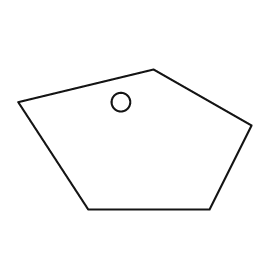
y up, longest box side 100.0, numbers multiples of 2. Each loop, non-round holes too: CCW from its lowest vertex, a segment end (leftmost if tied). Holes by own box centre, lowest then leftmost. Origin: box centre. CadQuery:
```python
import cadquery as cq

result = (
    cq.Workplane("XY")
    .moveTo(-20.0, -30.0)
    .lineTo(32.0, -30.0)
    .lineTo(50.0, 6.0)
    .lineTo(8.0, 30.0)
    .lineTo(-50.0, 16.0)
    .close()
    .moveTo(-6.0, 16.0)
    .circle(4.0)
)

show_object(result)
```